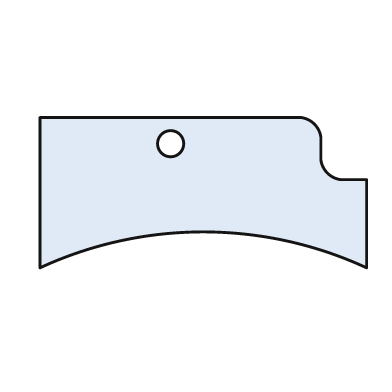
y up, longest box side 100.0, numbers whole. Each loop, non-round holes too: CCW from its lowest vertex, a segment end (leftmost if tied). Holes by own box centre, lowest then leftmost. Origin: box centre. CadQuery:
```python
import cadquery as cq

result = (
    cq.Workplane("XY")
    .moveTo(-50.0, -23.0)
    .threePointArc((0.0, -12.0), (50.0, -23.0))
    .lineTo(50.0, 4.0)
    .lineTo(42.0, 4.0)
    .threePointArc((38.0, 6.0), (36.0, 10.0))
    .lineTo(36.0, 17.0)
    .threePointArc((34.0, 21.0), (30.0, 23.0))
    .lineTo(-50.0, 23.0)
    .close()
    .moveTo(-10.0, 15.0)
    .circle(4.0)
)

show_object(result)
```